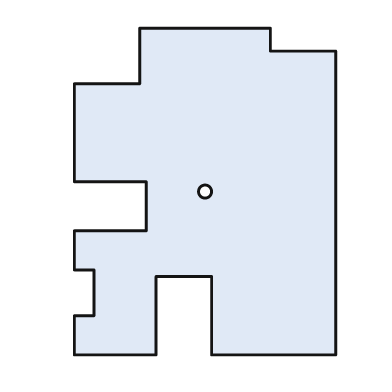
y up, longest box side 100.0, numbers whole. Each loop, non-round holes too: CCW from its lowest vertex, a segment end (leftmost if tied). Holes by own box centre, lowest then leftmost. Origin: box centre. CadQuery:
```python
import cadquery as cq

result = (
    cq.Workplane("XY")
    .moveTo(-40.0, -50.0)
    .lineTo(-15.0, -50.0)
    .lineTo(-15.0, -26.0)
    .lineTo(2.0, -26.0)
    .lineTo(2.0, -50.0)
    .lineTo(40.0, -50.0)
    .lineTo(40.0, 43.0)
    .lineTo(20.0, 43.0)
    .lineTo(20.0, 50.0)
    .lineTo(-20.0, 50.0)
    .lineTo(-20.0, 33.0)
    .lineTo(-40.0, 33.0)
    .lineTo(-40.0, 3.0)
    .lineTo(-18.0, 3.0)
    .lineTo(-18.0, -12.0)
    .lineTo(-40.0, -12.0)
    .lineTo(-40.0, -24.0)
    .lineTo(-34.0, -24.0)
    .lineTo(-34.0, -38.0)
    .lineTo(-40.0, -38.0)
    .close()
    .moveTo(0.0, 0.0)
    .circle(2.0)
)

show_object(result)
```